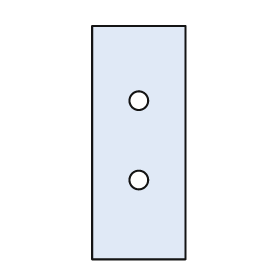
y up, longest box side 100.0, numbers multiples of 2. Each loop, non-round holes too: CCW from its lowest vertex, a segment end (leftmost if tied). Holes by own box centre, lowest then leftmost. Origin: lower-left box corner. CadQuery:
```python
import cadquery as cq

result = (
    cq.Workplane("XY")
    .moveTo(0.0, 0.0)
    .lineTo(40.0, 0.0)
    .lineTo(40.0, 100.0)
    .lineTo(0.0, 100.0)
    .close()
    .moveTo(20.0, 34.0)
    .circle(4.0)
    .moveTo(20.0, 68.0)
    .circle(4.0)
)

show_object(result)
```